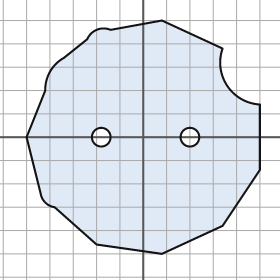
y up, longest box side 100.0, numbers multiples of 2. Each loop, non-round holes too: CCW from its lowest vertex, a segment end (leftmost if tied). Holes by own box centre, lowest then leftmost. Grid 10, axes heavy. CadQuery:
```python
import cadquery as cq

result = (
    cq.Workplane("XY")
    .moveTo(8.0, -50.0)
    .lineTo(34.0, -38.0)
    .lineTo(50.0, -14.0)
    .lineTo(50.0, 14.0)
    .threePointArc((36.0, 22.0), (34.0, 38.0))
    .lineTo(8.0, 50.0)
    .lineTo(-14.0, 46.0)
    .threePointArc((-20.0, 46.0), (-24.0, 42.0))
    .lineTo(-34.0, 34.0)
    .threePointArc((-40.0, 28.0), (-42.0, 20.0))
    .lineTo(-50.0, 0.0)
    .lineTo(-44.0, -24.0)
    .threePointArc((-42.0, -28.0), (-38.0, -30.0))
    .lineTo(-20.0, -46.0)
    .close()
    .moveTo(-18.0, 0.0)
    .circle(4.0)
    .moveTo(20.0, 0.0)
    .circle(4.0)
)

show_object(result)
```